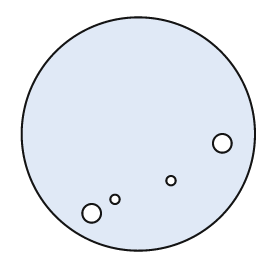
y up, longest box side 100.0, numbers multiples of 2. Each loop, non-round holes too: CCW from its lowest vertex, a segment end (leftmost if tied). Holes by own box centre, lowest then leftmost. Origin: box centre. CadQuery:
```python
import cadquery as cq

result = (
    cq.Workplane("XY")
    .moveTo(0.0, 0.0)
    .circle(50.0)
    .moveTo(-20.0, -34.0)
    .circle(4.0)
    .moveTo(-10.0, -28.0)
    .circle(2.0)
    .moveTo(14.0, -20.0)
    .circle(2.0)
    .moveTo(36.0, -4.0)
    .circle(4.0)
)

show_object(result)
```